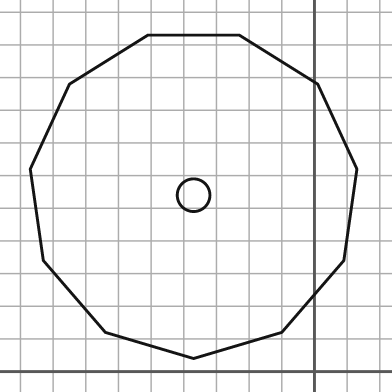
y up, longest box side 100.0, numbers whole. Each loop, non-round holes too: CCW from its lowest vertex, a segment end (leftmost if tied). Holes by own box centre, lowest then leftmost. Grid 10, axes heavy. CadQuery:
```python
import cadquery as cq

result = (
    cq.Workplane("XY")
    .moveTo(-37.0, 4.0)
    .lineTo(-10.0, 12.0)
    .lineTo(9.0, 34.0)
    .lineTo(13.0, 62.0)
    .lineTo(1.0, 88.0)
    .lineTo(-23.0, 103.0)
    .lineTo(-51.0, 103.0)
    .lineTo(-75.0, 88.0)
    .lineTo(-87.0, 62.0)
    .lineTo(-83.0, 34.0)
    .lineTo(-64.0, 12.0)
    .close()
    .moveTo(-37.0, 54.0)
    .circle(5.0)
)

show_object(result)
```